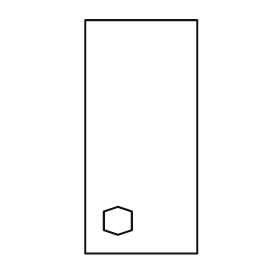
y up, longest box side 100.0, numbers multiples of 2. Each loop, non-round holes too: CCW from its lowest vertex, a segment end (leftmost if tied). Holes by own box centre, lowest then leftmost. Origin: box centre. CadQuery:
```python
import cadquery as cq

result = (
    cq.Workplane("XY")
    .moveTo(-24.0, -50.0)
    .lineTo(24.0, -50.0)
    .lineTo(24.0, 50.0)
    .lineTo(-24.0, 50.0)
    .close()
    .moveTo(-10.0, -42.0)
    .lineTo(-4.0, -40.0)
    .lineTo(-4.0, -32.0)
    .lineTo(-10.0, -30.0)
    .lineTo(-16.0, -32.0)
    .lineTo(-16.0, -40.0)
    .close()
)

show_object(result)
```